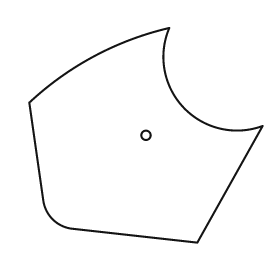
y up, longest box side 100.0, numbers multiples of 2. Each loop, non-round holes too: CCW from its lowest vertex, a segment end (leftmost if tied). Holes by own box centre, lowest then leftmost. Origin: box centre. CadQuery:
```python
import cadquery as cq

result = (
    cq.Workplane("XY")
    .moveTo(22.0, -46.0)
    .lineTo(50.0, 4.0)
    .threePointArc((16.0, 12.0), (10.0, 46.0))
    .threePointArc((-22.0, 34.0), (-50.0, 14.0))
    .lineTo(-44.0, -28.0)
    .threePointArc((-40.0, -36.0), (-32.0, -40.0))
    .close()
    .moveTo(0.0, 0.0)
    .circle(2.0)
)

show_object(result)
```